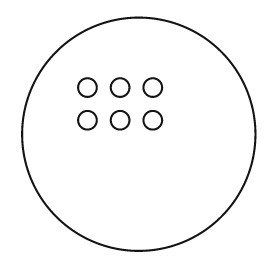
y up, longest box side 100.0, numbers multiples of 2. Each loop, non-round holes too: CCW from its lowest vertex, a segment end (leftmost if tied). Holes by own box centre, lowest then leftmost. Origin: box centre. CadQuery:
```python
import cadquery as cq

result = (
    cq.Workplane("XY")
    .moveTo(0.0, 0.0)
    .circle(50.0)
    .moveTo(-22.0, 6.0)
    .circle(4.0)
    .moveTo(-8.0, 6.0)
    .circle(4.0)
    .moveTo(6.0, 6.0)
    .circle(4.0)
    .moveTo(-22.0, 20.0)
    .circle(4.0)
    .moveTo(-8.0, 20.0)
    .circle(4.0)
    .moveTo(6.0, 20.0)
    .circle(4.0)
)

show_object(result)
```